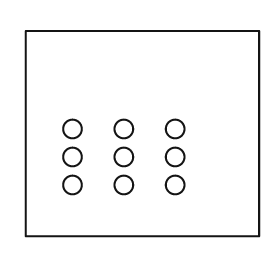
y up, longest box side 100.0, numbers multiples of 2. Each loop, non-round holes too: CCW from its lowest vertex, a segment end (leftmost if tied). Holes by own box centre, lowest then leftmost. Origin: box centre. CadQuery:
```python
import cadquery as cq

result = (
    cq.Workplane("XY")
    .moveTo(-50.0, -44.0)
    .lineTo(50.0, -44.0)
    .lineTo(50.0, 44.0)
    .lineTo(-50.0, 44.0)
    .close()
    .moveTo(-30.0, -22.0)
    .circle(4.0)
    .moveTo(-8.0, -22.0)
    .circle(4.0)
    .moveTo(14.0, -22.0)
    .circle(4.0)
    .moveTo(-30.0, -10.0)
    .circle(4.0)
    .moveTo(-8.0, -10.0)
    .circle(4.0)
    .moveTo(14.0, -10.0)
    .circle(4.0)
    .moveTo(-30.0, 2.0)
    .circle(4.0)
    .moveTo(-8.0, 2.0)
    .circle(4.0)
    .moveTo(14.0, 2.0)
    .circle(4.0)
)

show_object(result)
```